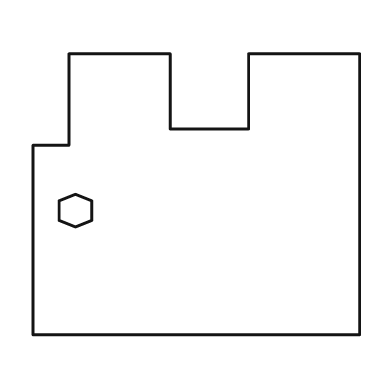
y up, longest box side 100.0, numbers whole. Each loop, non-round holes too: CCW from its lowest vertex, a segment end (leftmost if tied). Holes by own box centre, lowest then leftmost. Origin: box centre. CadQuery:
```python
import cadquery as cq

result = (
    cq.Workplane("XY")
    .moveTo(-50.0, -43.0)
    .lineTo(50.0, -43.0)
    .lineTo(50.0, 43.0)
    .lineTo(16.0, 43.0)
    .lineTo(16.0, 20.0)
    .lineTo(-8.0, 20.0)
    .lineTo(-8.0, 43.0)
    .lineTo(-39.0, 43.0)
    .lineTo(-39.0, 15.0)
    .lineTo(-50.0, 15.0)
    .close()
    .moveTo(-37.0, -10.0)
    .lineTo(-32.0, -8.0)
    .lineTo(-32.0, -2.0)
    .lineTo(-37.0, 0.0)
    .lineTo(-42.0, -2.0)
    .lineTo(-42.0, -8.0)
    .close()
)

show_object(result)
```